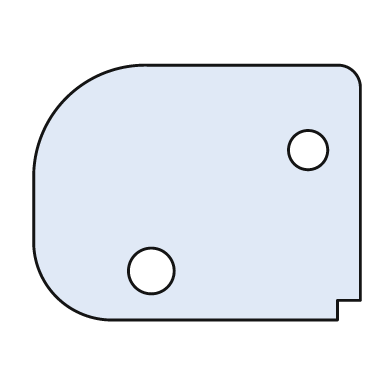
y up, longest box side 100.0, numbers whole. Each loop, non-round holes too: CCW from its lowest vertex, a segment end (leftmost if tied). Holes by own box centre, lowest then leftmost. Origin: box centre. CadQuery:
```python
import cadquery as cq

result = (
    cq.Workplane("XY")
    .moveTo(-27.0, -39.0)
    .lineTo(43.0, -39.0)
    .lineTo(43.0, -33.0)
    .lineTo(50.0, -33.0)
    .lineTo(50.0, 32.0)
    .threePointArc((48.0, 37.0), (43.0, 39.0))
    .lineTo(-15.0, 39.0)
    .threePointArc((-40.0, 29.0), (-50.0, 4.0))
    .lineTo(-50.0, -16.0)
    .threePointArc((-43.0, -32.0), (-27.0, -39.0))
    .close()
    .moveTo(-14.0, -24.0)
    .circle(7.0)
    .moveTo(34.0, 13.0)
    .circle(6.0)
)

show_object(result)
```